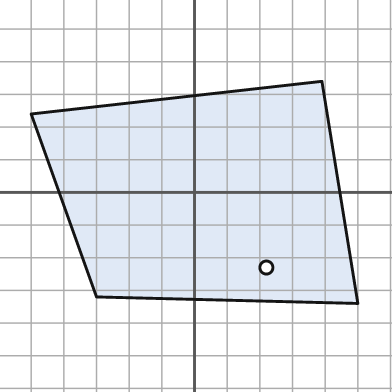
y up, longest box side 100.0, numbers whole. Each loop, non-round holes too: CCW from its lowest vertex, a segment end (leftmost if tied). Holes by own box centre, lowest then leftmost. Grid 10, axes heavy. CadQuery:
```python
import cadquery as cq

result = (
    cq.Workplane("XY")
    .moveTo(50.0, -34.0)
    .lineTo(39.0, 34.0)
    .lineTo(-50.0, 24.0)
    .lineTo(-30.0, -32.0)
    .close()
    .moveTo(22.0, -23.0)
    .circle(2.0)
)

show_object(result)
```